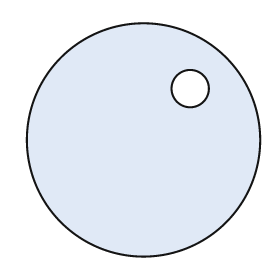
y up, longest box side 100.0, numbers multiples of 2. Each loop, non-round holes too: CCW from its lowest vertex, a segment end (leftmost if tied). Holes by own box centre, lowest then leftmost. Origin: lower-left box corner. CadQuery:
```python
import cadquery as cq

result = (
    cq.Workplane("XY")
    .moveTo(50.0, 50.0)
    .circle(50.0)
    .moveTo(70.0, 72.0)
    .circle(8.0)
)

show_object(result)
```